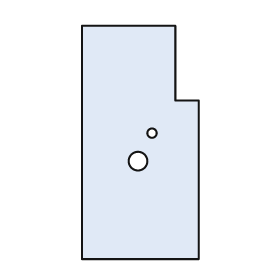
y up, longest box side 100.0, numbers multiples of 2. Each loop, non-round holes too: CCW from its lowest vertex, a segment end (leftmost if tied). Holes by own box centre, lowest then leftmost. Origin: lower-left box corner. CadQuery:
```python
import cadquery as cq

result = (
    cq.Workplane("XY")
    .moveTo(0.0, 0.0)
    .lineTo(50.0, 0.0)
    .lineTo(50.0, 68.0)
    .lineTo(40.0, 68.0)
    .lineTo(40.0, 100.0)
    .lineTo(0.0, 100.0)
    .close()
    .moveTo(24.0, 42.0)
    .circle(4.0)
    .moveTo(30.0, 54.0)
    .circle(2.0)
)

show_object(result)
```